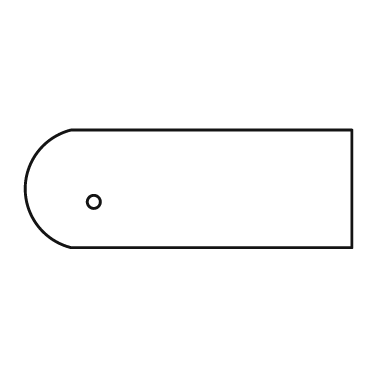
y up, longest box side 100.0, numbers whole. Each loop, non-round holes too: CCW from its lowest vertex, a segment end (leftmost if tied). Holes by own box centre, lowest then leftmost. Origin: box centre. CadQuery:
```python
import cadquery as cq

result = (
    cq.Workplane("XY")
    .moveTo(-36.0, -18.0)
    .lineTo(50.0, -18.0)
    .lineTo(50.0, 18.0)
    .lineTo(-36.0, 18.0)
    .threePointArc((-50.0, 0.0), (-36.0, -18.0))
    .close()
    .moveTo(-29.0, -4.0)
    .circle(2.0)
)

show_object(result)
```